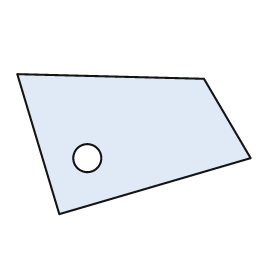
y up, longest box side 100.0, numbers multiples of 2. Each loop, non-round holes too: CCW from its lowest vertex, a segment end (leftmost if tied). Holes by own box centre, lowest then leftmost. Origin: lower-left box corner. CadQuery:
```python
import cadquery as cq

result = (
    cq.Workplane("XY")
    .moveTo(18.0, 0.0)
    .lineTo(100.0, 24.0)
    .lineTo(80.0, 58.0)
    .lineTo(0.0, 60.0)
    .close()
    .moveTo(30.0, 24.0)
    .circle(6.0)
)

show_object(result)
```